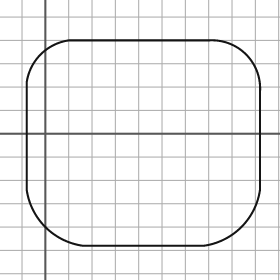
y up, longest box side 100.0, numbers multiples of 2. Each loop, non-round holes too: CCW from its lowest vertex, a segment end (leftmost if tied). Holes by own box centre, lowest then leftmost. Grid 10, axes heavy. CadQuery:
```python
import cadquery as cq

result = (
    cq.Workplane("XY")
    .moveTo(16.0, -48.0)
    .lineTo(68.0, -48.0)
    .threePointArc((84.0, -40.0), (92.0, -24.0))
    .lineTo(92.0, 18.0)
    .threePointArc((86.0, 34.0), (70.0, 40.0))
    .lineTo(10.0, 40.0)
    .threePointArc((-2.0, 34.0), (-8.0, 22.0))
    .lineTo(-8.0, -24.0)
    .threePointArc((0.0, -40.0), (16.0, -48.0))
    .close()
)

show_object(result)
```